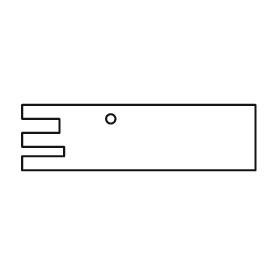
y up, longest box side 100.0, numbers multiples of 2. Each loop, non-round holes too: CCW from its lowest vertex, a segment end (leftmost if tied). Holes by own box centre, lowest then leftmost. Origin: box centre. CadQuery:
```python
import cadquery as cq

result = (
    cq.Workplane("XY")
    .moveTo(-50.0, -14.0)
    .lineTo(50.0, -14.0)
    .lineTo(50.0, 14.0)
    .lineTo(-50.0, 14.0)
    .lineTo(-50.0, 8.0)
    .lineTo(-34.0, 8.0)
    .lineTo(-34.0, 2.0)
    .lineTo(-50.0, 2.0)
    .lineTo(-50.0, -4.0)
    .lineTo(-32.0, -4.0)
    .lineTo(-32.0, -8.0)
    .lineTo(-50.0, -8.0)
    .close()
    .moveTo(-12.0, 8.0)
    .circle(2.0)
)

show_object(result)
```